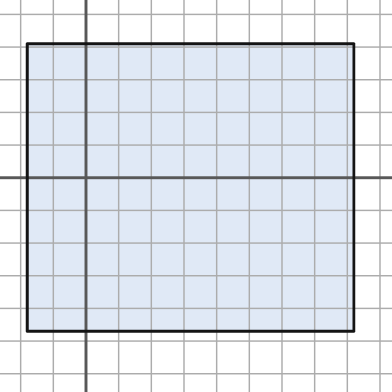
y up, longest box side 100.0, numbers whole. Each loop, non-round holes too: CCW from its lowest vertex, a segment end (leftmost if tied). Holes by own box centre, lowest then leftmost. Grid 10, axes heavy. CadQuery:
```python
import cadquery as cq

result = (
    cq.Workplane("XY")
    .moveTo(-18.0, -47.0)
    .lineTo(82.0, -47.0)
    .lineTo(82.0, 41.0)
    .lineTo(-18.0, 41.0)
    .close()
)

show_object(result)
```